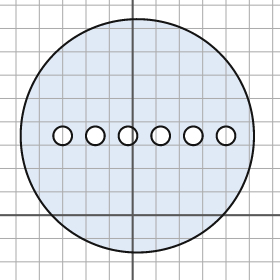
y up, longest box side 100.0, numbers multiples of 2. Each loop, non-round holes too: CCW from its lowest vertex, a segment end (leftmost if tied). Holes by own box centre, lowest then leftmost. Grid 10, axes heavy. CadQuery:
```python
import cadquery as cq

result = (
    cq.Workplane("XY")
    .moveTo(2.0, 34.0)
    .circle(50.0)
    .moveTo(-30.0, 34.0)
    .circle(4.0)
    .moveTo(-16.0, 34.0)
    .circle(4.0)
    .moveTo(-2.0, 34.0)
    .circle(4.0)
    .moveTo(12.0, 34.0)
    .circle(4.0)
    .moveTo(26.0, 34.0)
    .circle(4.0)
    .moveTo(40.0, 34.0)
    .circle(4.0)
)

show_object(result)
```